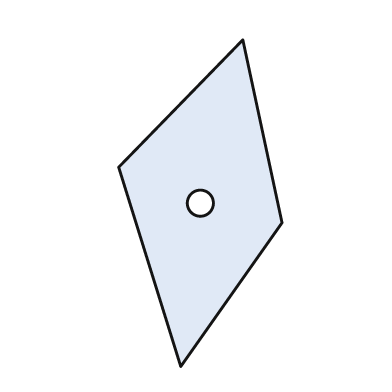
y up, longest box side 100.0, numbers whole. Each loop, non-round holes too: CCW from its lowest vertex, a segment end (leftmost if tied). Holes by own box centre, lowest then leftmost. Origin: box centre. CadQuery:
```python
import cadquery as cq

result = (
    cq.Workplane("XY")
    .moveTo(-6.0, -50.0)
    .lineTo(25.0, -6.0)
    .lineTo(13.0, 50.0)
    .lineTo(-25.0, 11.0)
    .close()
    .moveTo(0.0, 0.0)
    .circle(4.0)
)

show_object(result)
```